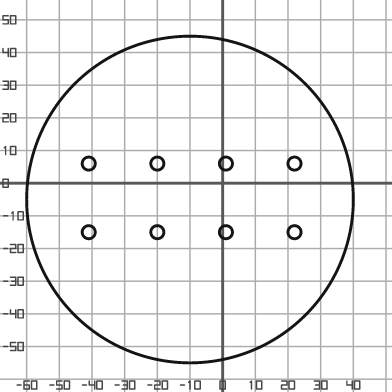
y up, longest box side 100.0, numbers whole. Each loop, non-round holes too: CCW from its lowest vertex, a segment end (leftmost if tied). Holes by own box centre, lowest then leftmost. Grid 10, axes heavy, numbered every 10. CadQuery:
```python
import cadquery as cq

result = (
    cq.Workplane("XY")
    .moveTo(-10.0, -5.0)
    .circle(50.0)
    .moveTo(-41.0, -15.0)
    .circle(2.0)
    .moveTo(-20.0, -15.0)
    .circle(2.0)
    .moveTo(1.0, -15.0)
    .circle(2.0)
    .moveTo(22.0, -15.0)
    .circle(2.0)
    .moveTo(-41.0, 6.0)
    .circle(2.0)
    .moveTo(-20.0, 6.0)
    .circle(2.0)
    .moveTo(1.0, 6.0)
    .circle(2.0)
    .moveTo(22.0, 6.0)
    .circle(2.0)
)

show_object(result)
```